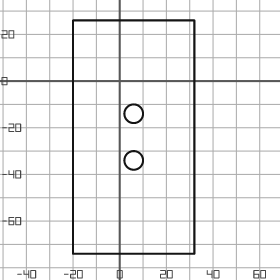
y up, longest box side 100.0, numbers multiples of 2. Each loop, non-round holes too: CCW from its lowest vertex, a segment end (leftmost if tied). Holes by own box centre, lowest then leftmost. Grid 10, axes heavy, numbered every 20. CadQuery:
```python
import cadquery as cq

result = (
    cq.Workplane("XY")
    .moveTo(-20.0, -74.0)
    .lineTo(32.0, -74.0)
    .lineTo(32.0, 26.0)
    .lineTo(-20.0, 26.0)
    .close()
    .moveTo(6.0, -34.0)
    .circle(4.0)
    .moveTo(6.0, -14.0)
    .circle(4.0)
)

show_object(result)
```